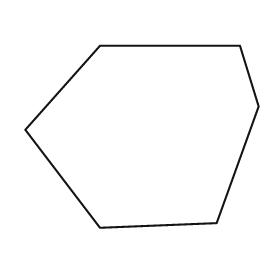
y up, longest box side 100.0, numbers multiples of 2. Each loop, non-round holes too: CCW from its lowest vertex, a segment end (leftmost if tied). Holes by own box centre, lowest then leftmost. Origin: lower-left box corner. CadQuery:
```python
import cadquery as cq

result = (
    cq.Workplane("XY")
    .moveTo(32.0, 0.0)
    .lineTo(82.0, 2.0)
    .lineTo(100.0, 52.0)
    .lineTo(92.0, 78.0)
    .lineTo(32.0, 78.0)
    .lineTo(0.0, 42.0)
    .close()
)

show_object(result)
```